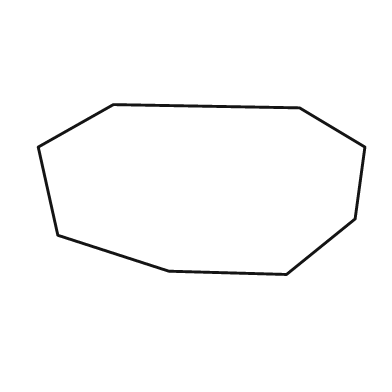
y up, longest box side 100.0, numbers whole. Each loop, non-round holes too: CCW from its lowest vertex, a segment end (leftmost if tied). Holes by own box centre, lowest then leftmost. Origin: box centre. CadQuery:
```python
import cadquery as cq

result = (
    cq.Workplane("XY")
    .moveTo(26.0, -26.0)
    .lineTo(47.0, -9.0)
    .lineTo(50.0, 13.0)
    .lineTo(30.0, 25.0)
    .lineTo(-27.0, 26.0)
    .lineTo(-50.0, 13.0)
    .lineTo(-44.0, -14.0)
    .lineTo(-10.0, -25.0)
    .close()
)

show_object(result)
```